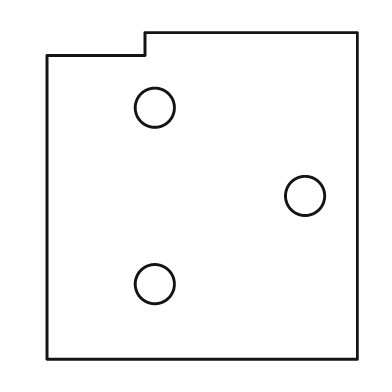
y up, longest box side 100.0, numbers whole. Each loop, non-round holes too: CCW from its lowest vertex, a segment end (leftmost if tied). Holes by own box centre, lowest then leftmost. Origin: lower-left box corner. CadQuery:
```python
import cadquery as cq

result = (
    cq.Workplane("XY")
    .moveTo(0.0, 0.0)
    .lineTo(95.0, 0.0)
    .lineTo(95.0, 100.0)
    .lineTo(30.0, 100.0)
    .lineTo(30.0, 93.0)
    .lineTo(0.0, 93.0)
    .close()
    .moveTo(33.0, 23.0)
    .circle(6.0)
    .moveTo(79.0, 50.0)
    .circle(6.0)
    .moveTo(33.0, 77.0)
    .circle(6.0)
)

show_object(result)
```